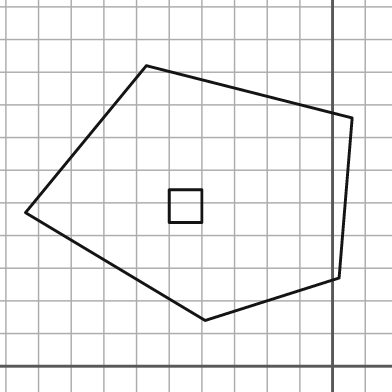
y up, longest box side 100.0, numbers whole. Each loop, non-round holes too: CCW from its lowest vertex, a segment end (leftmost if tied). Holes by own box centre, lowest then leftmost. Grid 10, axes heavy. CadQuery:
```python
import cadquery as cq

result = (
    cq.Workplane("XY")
    .moveTo(-39.0, 14.0)
    .lineTo(2.0, 27.0)
    .lineTo(6.0, 76.0)
    .lineTo(-57.0, 92.0)
    .lineTo(-94.0, 47.0)
    .close()
    .moveTo(-50.0, 44.0)
    .lineTo(-40.0, 44.0)
    .lineTo(-40.0, 54.0)
    .lineTo(-50.0, 54.0)
    .close()
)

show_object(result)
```